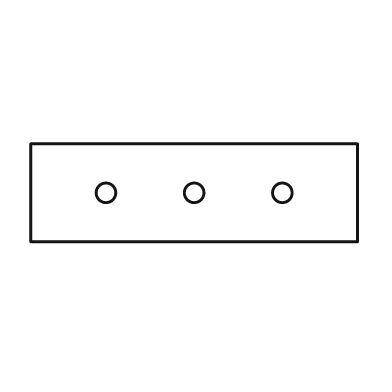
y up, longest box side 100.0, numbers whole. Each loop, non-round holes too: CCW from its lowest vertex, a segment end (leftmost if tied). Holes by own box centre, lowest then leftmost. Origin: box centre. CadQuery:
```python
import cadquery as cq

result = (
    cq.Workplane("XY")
    .moveTo(-50.0, -15.0)
    .lineTo(50.0, -15.0)
    .lineTo(50.0, 15.0)
    .lineTo(-50.0, 15.0)
    .close()
    .moveTo(-27.0, 0.0)
    .circle(3.0)
    .moveTo(0.0, 0.0)
    .circle(3.0)
    .moveTo(27.0, 0.0)
    .circle(3.0)
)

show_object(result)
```